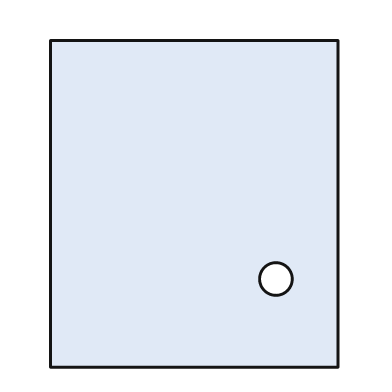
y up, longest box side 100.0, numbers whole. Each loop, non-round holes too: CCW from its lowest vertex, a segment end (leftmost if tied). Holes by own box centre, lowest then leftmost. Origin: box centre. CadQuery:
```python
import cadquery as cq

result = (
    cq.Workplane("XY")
    .moveTo(-44.0, -50.0)
    .lineTo(44.0, -50.0)
    .lineTo(44.0, 50.0)
    .lineTo(-44.0, 50.0)
    .close()
    .moveTo(25.0, -23.0)
    .circle(5.0)
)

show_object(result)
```